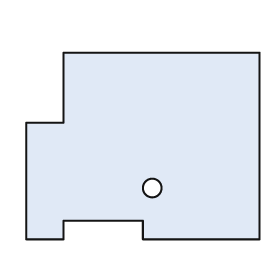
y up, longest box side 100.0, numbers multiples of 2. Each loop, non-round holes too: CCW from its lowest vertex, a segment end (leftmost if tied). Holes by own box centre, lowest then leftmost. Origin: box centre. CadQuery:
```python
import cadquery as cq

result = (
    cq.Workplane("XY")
    .moveTo(-50.0, -40.0)
    .lineTo(-34.0, -40.0)
    .lineTo(-34.0, -32.0)
    .lineTo(0.0, -32.0)
    .lineTo(0.0, -40.0)
    .lineTo(50.0, -40.0)
    .lineTo(50.0, 40.0)
    .lineTo(-34.0, 40.0)
    .lineTo(-34.0, 10.0)
    .lineTo(-50.0, 10.0)
    .close()
    .moveTo(4.0, -18.0)
    .circle(4.0)
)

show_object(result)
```